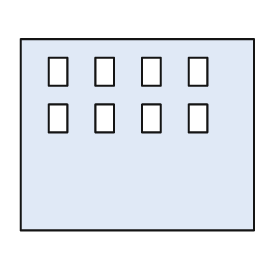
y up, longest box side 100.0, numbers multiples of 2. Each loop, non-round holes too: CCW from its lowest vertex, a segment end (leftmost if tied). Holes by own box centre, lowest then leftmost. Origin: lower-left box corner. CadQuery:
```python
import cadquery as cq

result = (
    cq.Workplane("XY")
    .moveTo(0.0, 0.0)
    .lineTo(100.0, 0.0)
    .lineTo(100.0, 82.0)
    .lineTo(0.0, 82.0)
    .close()
    .moveTo(12.0, 42.0)
    .lineTo(20.0, 42.0)
    .lineTo(20.0, 54.0)
    .lineTo(12.0, 54.0)
    .close()
    .moveTo(32.0, 42.0)
    .lineTo(40.0, 42.0)
    .lineTo(40.0, 54.0)
    .lineTo(32.0, 54.0)
    .close()
    .moveTo(52.0, 42.0)
    .lineTo(60.0, 42.0)
    .lineTo(60.0, 54.0)
    .lineTo(52.0, 54.0)
    .close()
    .moveTo(72.0, 42.0)
    .lineTo(80.0, 42.0)
    .lineTo(80.0, 54.0)
    .lineTo(72.0, 54.0)
    .close()
    .moveTo(12.0, 62.0)
    .lineTo(20.0, 62.0)
    .lineTo(20.0, 74.0)
    .lineTo(12.0, 74.0)
    .close()
    .moveTo(32.0, 62.0)
    .lineTo(40.0, 62.0)
    .lineTo(40.0, 74.0)
    .lineTo(32.0, 74.0)
    .close()
    .moveTo(52.0, 62.0)
    .lineTo(60.0, 62.0)
    .lineTo(60.0, 74.0)
    .lineTo(52.0, 74.0)
    .close()
    .moveTo(72.0, 62.0)
    .lineTo(80.0, 62.0)
    .lineTo(80.0, 74.0)
    .lineTo(72.0, 74.0)
    .close()
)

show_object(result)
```